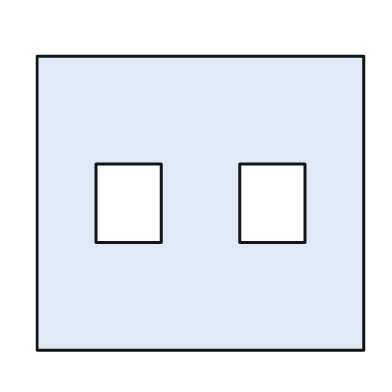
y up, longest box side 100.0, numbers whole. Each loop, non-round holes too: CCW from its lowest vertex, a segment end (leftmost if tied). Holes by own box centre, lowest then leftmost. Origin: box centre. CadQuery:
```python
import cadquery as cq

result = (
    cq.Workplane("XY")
    .moveTo(-50.0, -45.0)
    .lineTo(50.0, -45.0)
    .lineTo(50.0, 45.0)
    .lineTo(-50.0, 45.0)
    .close()
    .moveTo(-32.0, -12.0)
    .lineTo(-12.0, -12.0)
    .lineTo(-12.0, 12.0)
    .lineTo(-32.0, 12.0)
    .close()
    .moveTo(12.0, -12.0)
    .lineTo(32.0, -12.0)
    .lineTo(32.0, 12.0)
    .lineTo(12.0, 12.0)
    .close()
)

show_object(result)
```